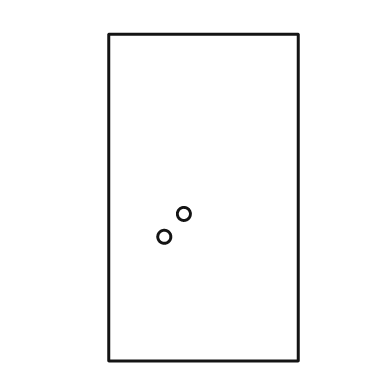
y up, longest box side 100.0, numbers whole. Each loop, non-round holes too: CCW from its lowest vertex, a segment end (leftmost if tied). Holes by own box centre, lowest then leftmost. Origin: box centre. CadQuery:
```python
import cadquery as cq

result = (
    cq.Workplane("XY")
    .moveTo(-29.0, -50.0)
    .lineTo(29.0, -50.0)
    .lineTo(29.0, 50.0)
    .lineTo(-29.0, 50.0)
    .close()
    .moveTo(-12.0, -12.0)
    .circle(2.0)
    .moveTo(-6.0, -5.0)
    .circle(2.0)
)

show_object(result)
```